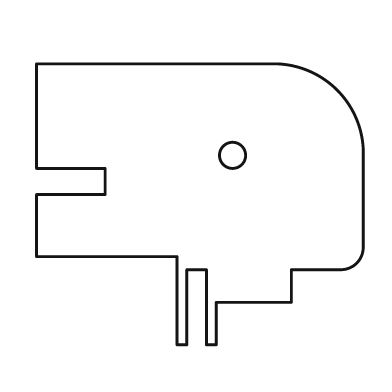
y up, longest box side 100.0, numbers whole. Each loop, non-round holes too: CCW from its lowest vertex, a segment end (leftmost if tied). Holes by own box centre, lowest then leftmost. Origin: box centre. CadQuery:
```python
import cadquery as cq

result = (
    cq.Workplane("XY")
    .moveTo(-7.0, -43.0)
    .lineTo(-4.0, -43.0)
    .lineTo(-4.0, -20.0)
    .lineTo(2.0, -20.0)
    .lineTo(2.0, -43.0)
    .lineTo(5.0, -43.0)
    .lineTo(5.0, -30.0)
    .lineTo(28.0, -30.0)
    .lineTo(28.0, -20.0)
    .lineTo(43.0, -20.0)
    .threePointArc((48.0, -18.0), (50.0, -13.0))
    .lineTo(50.0, 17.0)
    .threePointArc((42.0, 35.0), (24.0, 43.0))
    .lineTo(-50.0, 43.0)
    .lineTo(-50.0, 11.0)
    .lineTo(-29.0, 11.0)
    .lineTo(-29.0, 3.0)
    .lineTo(-50.0, 3.0)
    .lineTo(-50.0, -16.0)
    .lineTo(-7.0, -16.0)
    .close()
    .moveTo(10.0, 15.0)
    .circle(4.0)
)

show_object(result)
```